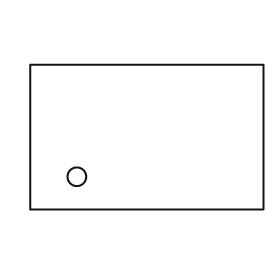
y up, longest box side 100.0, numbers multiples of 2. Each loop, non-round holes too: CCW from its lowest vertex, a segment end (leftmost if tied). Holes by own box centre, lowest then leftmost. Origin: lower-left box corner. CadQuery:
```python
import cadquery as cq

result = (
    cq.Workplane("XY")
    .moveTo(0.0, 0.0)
    .lineTo(100.0, 0.0)
    .lineTo(100.0, 62.0)
    .lineTo(0.0, 62.0)
    .close()
    .moveTo(20.0, 14.0)
    .circle(4.0)
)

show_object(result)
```